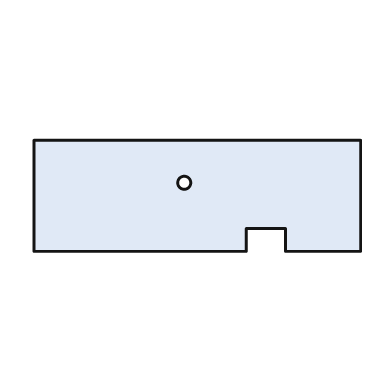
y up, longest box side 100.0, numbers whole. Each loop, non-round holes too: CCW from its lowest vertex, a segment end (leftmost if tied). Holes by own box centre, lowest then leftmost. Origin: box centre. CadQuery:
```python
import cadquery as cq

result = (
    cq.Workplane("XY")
    .moveTo(-50.0, -17.0)
    .lineTo(15.0, -17.0)
    .lineTo(15.0, -10.0)
    .lineTo(27.0, -10.0)
    .lineTo(27.0, -17.0)
    .lineTo(50.0, -17.0)
    .lineTo(50.0, 17.0)
    .lineTo(-50.0, 17.0)
    .close()
    .moveTo(-4.0, 4.0)
    .circle(2.0)
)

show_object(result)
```